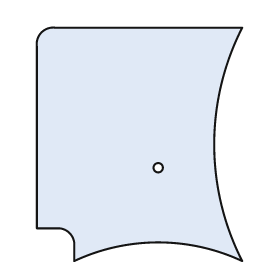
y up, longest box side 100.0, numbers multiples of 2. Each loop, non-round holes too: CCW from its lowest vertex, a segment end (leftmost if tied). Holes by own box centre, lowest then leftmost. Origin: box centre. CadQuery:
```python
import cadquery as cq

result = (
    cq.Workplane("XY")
    .moveTo(-28.0, -50.0)
    .threePointArc((8.0, -42.0), (44.0, -50.0))
    .threePointArc((32.0, 0.0), (44.0, 50.0))
    .lineTo(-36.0, 50.0)
    .threePointArc((-42.0, 48.0), (-44.0, 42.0))
    .lineTo(-44.0, -36.0)
    .lineTo(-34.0, -36.0)
    .threePointArc((-30.0, -38.0), (-28.0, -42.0))
    .close()
    .moveTo(8.0, -10.0)
    .circle(2.0)
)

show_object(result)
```